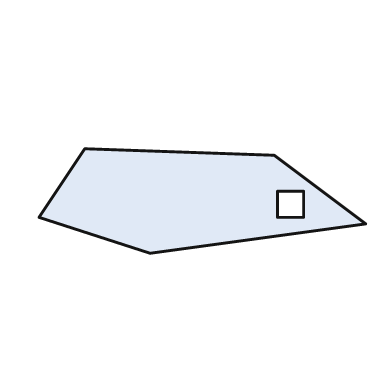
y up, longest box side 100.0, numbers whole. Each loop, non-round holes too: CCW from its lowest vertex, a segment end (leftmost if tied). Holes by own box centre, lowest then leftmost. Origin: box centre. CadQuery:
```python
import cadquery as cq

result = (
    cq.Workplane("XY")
    .moveTo(-16.0, -16.0)
    .lineTo(50.0, -7.0)
    .lineTo(22.0, 14.0)
    .lineTo(-36.0, 16.0)
    .lineTo(-50.0, -5.0)
    .close()
    .moveTo(23.0, -5.0)
    .lineTo(31.0, -5.0)
    .lineTo(31.0, 3.0)
    .lineTo(23.0, 3.0)
    .close()
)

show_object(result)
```